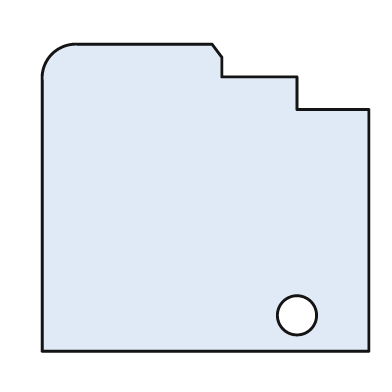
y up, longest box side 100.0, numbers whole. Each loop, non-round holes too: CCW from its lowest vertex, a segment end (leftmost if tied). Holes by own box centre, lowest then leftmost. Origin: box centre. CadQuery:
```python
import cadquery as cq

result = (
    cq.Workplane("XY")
    .moveTo(-50.0, -47.0)
    .lineTo(50.0, -47.0)
    .lineTo(50.0, 27.0)
    .lineTo(28.0, 27.0)
    .lineTo(28.0, 37.0)
    .lineTo(5.0, 37.0)
    .lineTo(5.0, 43.0)
    .lineTo(2.0, 47.0)
    .lineTo(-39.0, 47.0)
    .threePointArc((-47.0, 44.0), (-50.0, 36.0))
    .close()
    .moveTo(28.0, -36.0)
    .circle(6.0)
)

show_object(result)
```